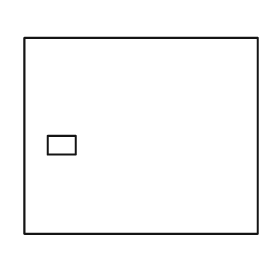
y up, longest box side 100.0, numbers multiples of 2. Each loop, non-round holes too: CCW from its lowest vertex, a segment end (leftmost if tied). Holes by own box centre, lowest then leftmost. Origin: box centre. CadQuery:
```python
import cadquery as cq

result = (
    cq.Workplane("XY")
    .moveTo(-50.0, -42.0)
    .lineTo(50.0, -42.0)
    .lineTo(50.0, 42.0)
    .lineTo(-50.0, 42.0)
    .close()
    .moveTo(-40.0, -8.0)
    .lineTo(-28.0, -8.0)
    .lineTo(-28.0, 0.0)
    .lineTo(-40.0, 0.0)
    .close()
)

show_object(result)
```